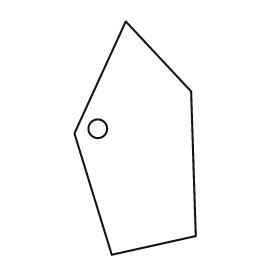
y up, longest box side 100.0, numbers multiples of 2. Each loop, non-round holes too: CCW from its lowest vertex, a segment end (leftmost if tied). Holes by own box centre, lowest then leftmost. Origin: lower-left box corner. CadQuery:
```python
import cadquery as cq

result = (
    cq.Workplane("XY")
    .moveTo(16.0, 0.0)
    .lineTo(52.0, 8.0)
    .lineTo(50.0, 70.0)
    .lineTo(22.0, 100.0)
    .lineTo(0.0, 52.0)
    .close()
    .moveTo(10.0, 54.0)
    .circle(4.0)
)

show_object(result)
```